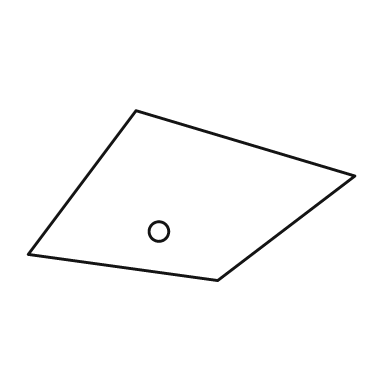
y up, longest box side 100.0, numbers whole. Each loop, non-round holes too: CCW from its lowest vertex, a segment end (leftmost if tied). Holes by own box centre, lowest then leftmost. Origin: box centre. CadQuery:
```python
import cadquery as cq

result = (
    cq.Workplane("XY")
    .moveTo(8.0, -26.0)
    .lineTo(50.0, 6.0)
    .lineTo(-17.0, 26.0)
    .lineTo(-50.0, -18.0)
    .close()
    .moveTo(-10.0, -11.0)
    .circle(3.0)
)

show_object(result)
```